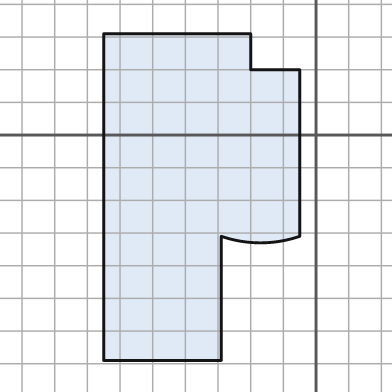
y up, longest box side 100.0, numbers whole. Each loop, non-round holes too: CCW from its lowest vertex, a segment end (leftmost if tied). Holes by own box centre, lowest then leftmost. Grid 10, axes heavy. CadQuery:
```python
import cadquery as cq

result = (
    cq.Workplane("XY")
    .moveTo(-65.0, -69.0)
    .lineTo(-29.0, -69.0)
    .lineTo(-29.0, -31.0)
    .threePointArc((-17.0, -33.0), (-5.0, -31.0))
    .lineTo(-5.0, 20.0)
    .lineTo(-20.0, 20.0)
    .lineTo(-20.0, 31.0)
    .lineTo(-65.0, 31.0)
    .close()
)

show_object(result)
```